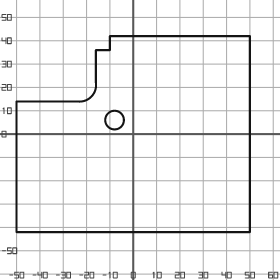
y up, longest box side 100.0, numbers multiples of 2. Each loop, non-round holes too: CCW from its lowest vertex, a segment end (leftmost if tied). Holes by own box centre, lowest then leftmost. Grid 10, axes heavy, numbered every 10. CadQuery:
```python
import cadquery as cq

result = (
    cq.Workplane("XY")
    .moveTo(-50.0, -42.0)
    .lineTo(50.0, -42.0)
    .lineTo(50.0, 42.0)
    .lineTo(-10.0, 42.0)
    .lineTo(-10.0, 36.0)
    .lineTo(-16.0, 36.0)
    .lineTo(-16.0, 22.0)
    .threePointArc((-18.0, 16.0), (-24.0, 14.0))
    .lineTo(-50.0, 14.0)
    .close()
    .moveTo(-8.0, 6.0)
    .circle(4.0)
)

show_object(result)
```